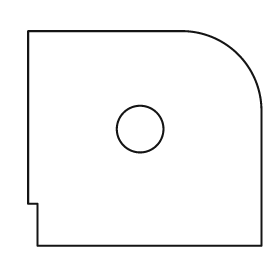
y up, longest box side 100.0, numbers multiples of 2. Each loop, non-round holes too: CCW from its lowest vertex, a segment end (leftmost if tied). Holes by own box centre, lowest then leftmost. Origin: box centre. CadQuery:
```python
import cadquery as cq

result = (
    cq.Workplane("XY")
    .moveTo(-46.0, -46.0)
    .lineTo(50.0, -46.0)
    .lineTo(50.0, 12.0)
    .threePointArc((40.0, 36.0), (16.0, 46.0))
    .lineTo(-50.0, 46.0)
    .lineTo(-50.0, -28.0)
    .lineTo(-46.0, -28.0)
    .close()
    .moveTo(-2.0, 4.0)
    .circle(10.0)
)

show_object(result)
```